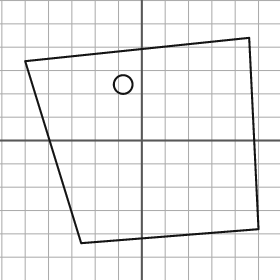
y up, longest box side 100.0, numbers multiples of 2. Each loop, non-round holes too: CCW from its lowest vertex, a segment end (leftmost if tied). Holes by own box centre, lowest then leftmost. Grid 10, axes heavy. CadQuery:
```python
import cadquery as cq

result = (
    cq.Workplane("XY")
    .moveTo(-26.0, -44.0)
    .lineTo(50.0, -38.0)
    .lineTo(46.0, 44.0)
    .lineTo(-50.0, 34.0)
    .close()
    .moveTo(-8.0, 24.0)
    .circle(4.0)
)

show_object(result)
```